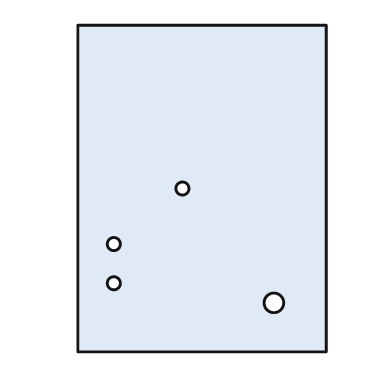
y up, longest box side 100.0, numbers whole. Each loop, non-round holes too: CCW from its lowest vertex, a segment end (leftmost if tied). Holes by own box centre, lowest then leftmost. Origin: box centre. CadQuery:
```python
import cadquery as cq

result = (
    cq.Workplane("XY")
    .moveTo(-38.0, -50.0)
    .lineTo(38.0, -50.0)
    .lineTo(38.0, 50.0)
    .lineTo(-38.0, 50.0)
    .close()
    .moveTo(22.0, -35.0)
    .circle(3.0)
    .moveTo(-27.0, -29.0)
    .circle(2.0)
    .moveTo(-27.0, -17.0)
    .circle(2.0)
    .moveTo(-6.0, 0.0)
    .circle(2.0)
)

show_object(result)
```